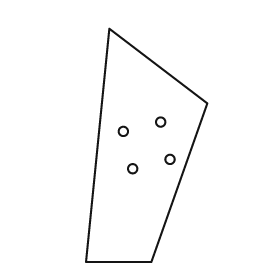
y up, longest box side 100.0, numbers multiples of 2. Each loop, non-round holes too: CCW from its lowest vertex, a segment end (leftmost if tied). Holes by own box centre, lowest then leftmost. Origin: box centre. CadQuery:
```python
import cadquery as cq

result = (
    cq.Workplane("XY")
    .moveTo(-26.0, -50.0)
    .lineTo(2.0, -50.0)
    .lineTo(26.0, 18.0)
    .lineTo(-16.0, 50.0)
    .close()
    .moveTo(-6.0, -10.0)
    .circle(2.0)
    .moveTo(10.0, -6.0)
    .circle(2.0)
    .moveTo(-10.0, 6.0)
    .circle(2.0)
    .moveTo(6.0, 10.0)
    .circle(2.0)
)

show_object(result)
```